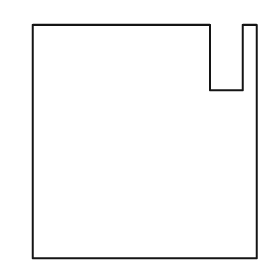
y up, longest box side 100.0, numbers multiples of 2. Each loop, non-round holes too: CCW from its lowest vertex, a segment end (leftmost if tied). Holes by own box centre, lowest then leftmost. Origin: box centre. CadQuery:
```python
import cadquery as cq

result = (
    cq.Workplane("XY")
    .moveTo(-48.0, -50.0)
    .lineTo(48.0, -50.0)
    .lineTo(48.0, 50.0)
    .lineTo(42.0, 50.0)
    .lineTo(42.0, 22.0)
    .lineTo(28.0, 22.0)
    .lineTo(28.0, 50.0)
    .lineTo(-48.0, 50.0)
    .close()
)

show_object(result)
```